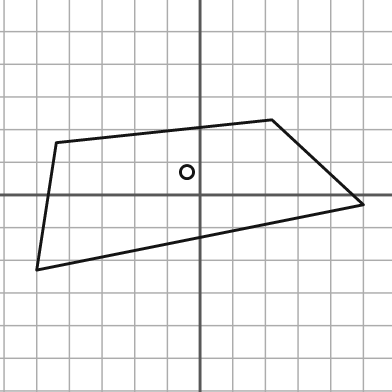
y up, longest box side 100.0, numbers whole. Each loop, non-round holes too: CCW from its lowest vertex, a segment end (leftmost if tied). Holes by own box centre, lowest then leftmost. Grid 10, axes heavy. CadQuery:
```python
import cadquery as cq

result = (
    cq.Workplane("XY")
    .moveTo(-50.0, -23.0)
    .lineTo(50.0, -3.0)
    .lineTo(22.0, 23.0)
    .lineTo(-44.0, 16.0)
    .close()
    .moveTo(-4.0, 7.0)
    .circle(2.0)
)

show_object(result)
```